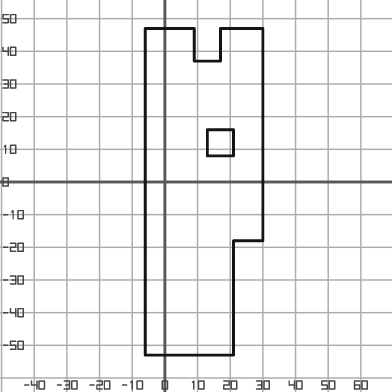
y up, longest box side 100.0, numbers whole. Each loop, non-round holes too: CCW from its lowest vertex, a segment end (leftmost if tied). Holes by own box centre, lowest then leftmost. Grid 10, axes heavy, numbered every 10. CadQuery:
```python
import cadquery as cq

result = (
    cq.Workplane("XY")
    .moveTo(-6.0, -53.0)
    .lineTo(21.0, -53.0)
    .lineTo(21.0, -18.0)
    .lineTo(30.0, -18.0)
    .lineTo(30.0, 47.0)
    .lineTo(17.0, 47.0)
    .lineTo(17.0, 37.0)
    .lineTo(9.0, 37.0)
    .lineTo(9.0, 47.0)
    .lineTo(-6.0, 47.0)
    .close()
    .moveTo(13.0, 8.0)
    .lineTo(21.0, 8.0)
    .lineTo(21.0, 16.0)
    .lineTo(13.0, 16.0)
    .close()
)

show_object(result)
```